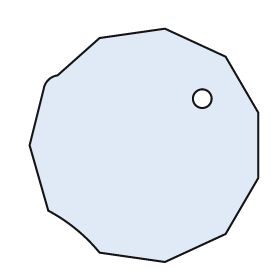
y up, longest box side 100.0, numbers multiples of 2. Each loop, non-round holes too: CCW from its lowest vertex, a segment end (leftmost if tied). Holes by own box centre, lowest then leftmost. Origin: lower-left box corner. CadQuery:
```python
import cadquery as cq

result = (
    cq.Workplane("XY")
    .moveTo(58.0, 0.0)
    .lineTo(84.0, 12.0)
    .lineTo(98.0, 36.0)
    .lineTo(98.0, 64.0)
    .lineTo(84.0, 88.0)
    .lineTo(58.0, 100.0)
    .lineTo(30.0, 96.0)
    .lineTo(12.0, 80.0)
    .threePointArc((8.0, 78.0), (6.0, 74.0))
    .lineTo(0.0, 50.0)
    .lineTo(8.0, 22.0)
    .threePointArc((20.0, 14.0), (30.0, 4.0))
    .close()
    .moveTo(74.0, 70.0)
    .circle(4.0)
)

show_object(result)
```